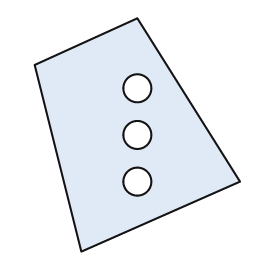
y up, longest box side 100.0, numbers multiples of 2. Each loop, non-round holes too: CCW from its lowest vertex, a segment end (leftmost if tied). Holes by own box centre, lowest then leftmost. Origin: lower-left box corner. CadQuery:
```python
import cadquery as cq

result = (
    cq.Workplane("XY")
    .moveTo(20.0, 0.0)
    .lineTo(88.0, 30.0)
    .lineTo(44.0, 100.0)
    .lineTo(0.0, 80.0)
    .close()
    .moveTo(44.0, 30.0)
    .circle(6.0)
    .moveTo(44.0, 50.0)
    .circle(6.0)
    .moveTo(44.0, 70.0)
    .circle(6.0)
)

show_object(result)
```